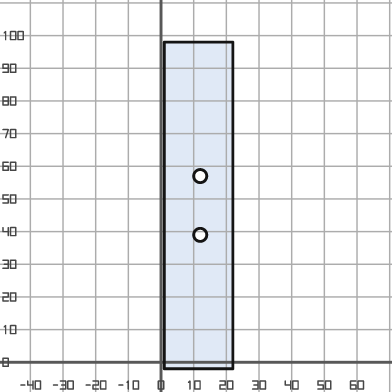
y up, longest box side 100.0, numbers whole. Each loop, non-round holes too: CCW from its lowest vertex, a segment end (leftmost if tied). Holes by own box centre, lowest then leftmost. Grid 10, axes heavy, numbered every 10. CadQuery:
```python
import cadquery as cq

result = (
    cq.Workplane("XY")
    .moveTo(1.0, -2.0)
    .lineTo(22.0, -2.0)
    .lineTo(22.0, 98.0)
    .lineTo(1.0, 98.0)
    .close()
    .moveTo(12.0, 39.0)
    .circle(2.0)
    .moveTo(12.0, 57.0)
    .circle(2.0)
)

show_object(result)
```